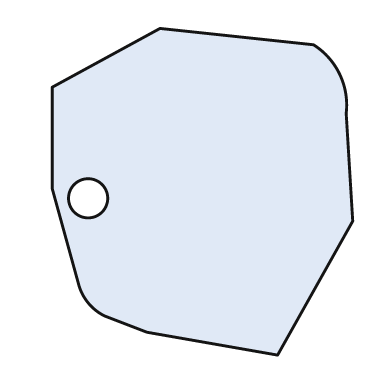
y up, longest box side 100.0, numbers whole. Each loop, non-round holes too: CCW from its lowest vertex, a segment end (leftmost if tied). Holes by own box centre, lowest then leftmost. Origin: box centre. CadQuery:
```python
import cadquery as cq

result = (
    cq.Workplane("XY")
    .moveTo(23.0, -50.0)
    .lineTo(46.0, -9.0)
    .lineTo(44.0, 24.0)
    .threePointArc((42.0, 36.0), (34.0, 45.0))
    .lineTo(-13.0, 50.0)
    .lineTo(-46.0, 32.0)
    .lineTo(-46.0, 1.0)
    .lineTo(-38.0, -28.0)
    .threePointArc((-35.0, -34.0), (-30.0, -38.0))
    .lineTo(-17.0, -43.0)
    .close()
    .moveTo(-35.0, -2.0)
    .circle(6.0)
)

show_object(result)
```